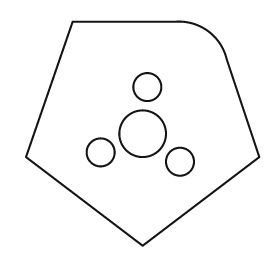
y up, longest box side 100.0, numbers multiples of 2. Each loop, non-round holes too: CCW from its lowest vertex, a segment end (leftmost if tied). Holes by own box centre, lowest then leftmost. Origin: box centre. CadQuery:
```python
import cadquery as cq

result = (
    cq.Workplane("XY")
    .moveTo(0.0, -48.0)
    .lineTo(50.0, -10.0)
    .lineTo(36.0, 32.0)
    .threePointArc((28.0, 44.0), (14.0, 48.0))
    .lineTo(-30.0, 48.0)
    .lineTo(-50.0, -10.0)
    .close()
    .moveTo(16.0, -12.0)
    .circle(6.0)
    .moveTo(-18.0, -8.0)
    .circle(6.0)
    .moveTo(0.0, 0.0)
    .circle(10.0)
    .moveTo(2.0, 20.0)
    .circle(6.0)
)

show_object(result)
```